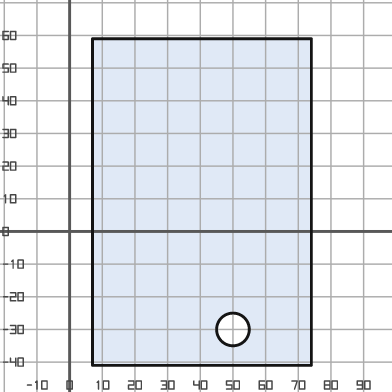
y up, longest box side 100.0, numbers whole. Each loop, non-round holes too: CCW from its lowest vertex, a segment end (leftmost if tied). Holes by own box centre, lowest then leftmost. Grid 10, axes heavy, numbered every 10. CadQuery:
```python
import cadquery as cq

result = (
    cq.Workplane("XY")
    .moveTo(7.0, -41.0)
    .lineTo(74.0, -41.0)
    .lineTo(74.0, 59.0)
    .lineTo(7.0, 59.0)
    .close()
    .moveTo(50.0, -30.0)
    .circle(5.0)
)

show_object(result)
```